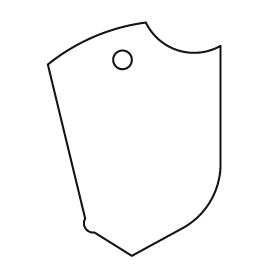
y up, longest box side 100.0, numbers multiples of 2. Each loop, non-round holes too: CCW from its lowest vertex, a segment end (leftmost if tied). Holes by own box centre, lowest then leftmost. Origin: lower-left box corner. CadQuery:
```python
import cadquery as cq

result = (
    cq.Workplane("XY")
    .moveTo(36.0, 0.0)
    .lineTo(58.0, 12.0)
    .threePointArc((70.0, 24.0), (74.0, 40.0))
    .lineTo(74.0, 90.0)
    .threePointArc((56.0, 88.0), (42.0, 100.0))
    .threePointArc((20.0, 94.0), (0.0, 82.0))
    .lineTo(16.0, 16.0)
    .threePointArc((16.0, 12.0), (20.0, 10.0))
    .close()
    .moveTo(32.0, 84.0)
    .circle(4.0)
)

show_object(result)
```